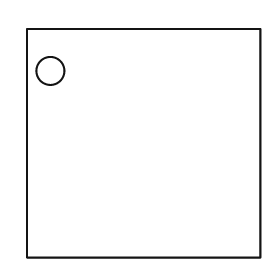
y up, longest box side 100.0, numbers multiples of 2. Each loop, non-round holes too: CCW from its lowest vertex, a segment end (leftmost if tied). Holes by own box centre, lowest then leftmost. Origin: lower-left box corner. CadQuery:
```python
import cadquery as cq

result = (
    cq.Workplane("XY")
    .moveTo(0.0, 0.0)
    .lineTo(100.0, 0.0)
    .lineTo(100.0, 98.0)
    .lineTo(0.0, 98.0)
    .close()
    .moveTo(10.0, 80.0)
    .circle(6.0)
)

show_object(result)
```